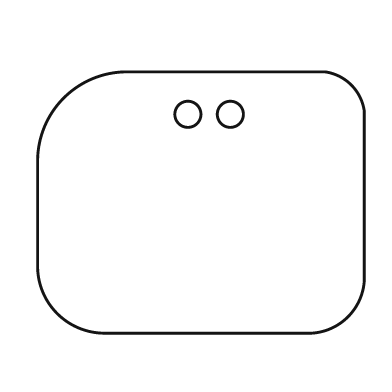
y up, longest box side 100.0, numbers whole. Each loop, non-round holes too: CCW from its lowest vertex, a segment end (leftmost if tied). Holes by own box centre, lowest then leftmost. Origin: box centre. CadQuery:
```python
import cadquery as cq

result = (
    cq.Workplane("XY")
    .moveTo(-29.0, -40.0)
    .lineTo(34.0, -40.0)
    .threePointArc((45.0, -35.0), (50.0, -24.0))
    .lineTo(50.0, 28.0)
    .threePointArc((46.0, 36.0), (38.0, 40.0))
    .lineTo(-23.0, 40.0)
    .threePointArc((-42.0, 32.0), (-50.0, 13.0))
    .lineTo(-50.0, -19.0)
    .threePointArc((-44.0, -34.0), (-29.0, -40.0))
    .close()
    .moveTo(-4.0, 27.0)
    .circle(4.0)
    .moveTo(9.0, 27.0)
    .circle(4.0)
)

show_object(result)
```